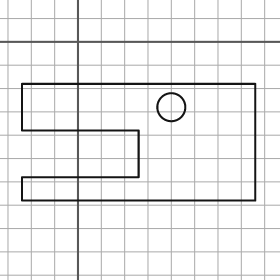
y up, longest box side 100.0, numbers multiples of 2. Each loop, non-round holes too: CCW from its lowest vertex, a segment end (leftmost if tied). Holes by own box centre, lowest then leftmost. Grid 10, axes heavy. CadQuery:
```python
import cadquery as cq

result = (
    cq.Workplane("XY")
    .moveTo(-24.0, -68.0)
    .lineTo(76.0, -68.0)
    .lineTo(76.0, -18.0)
    .lineTo(-24.0, -18.0)
    .lineTo(-24.0, -38.0)
    .lineTo(26.0, -38.0)
    .lineTo(26.0, -58.0)
    .lineTo(-24.0, -58.0)
    .close()
    .moveTo(40.0, -28.0)
    .circle(6.0)
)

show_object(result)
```